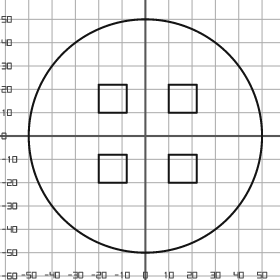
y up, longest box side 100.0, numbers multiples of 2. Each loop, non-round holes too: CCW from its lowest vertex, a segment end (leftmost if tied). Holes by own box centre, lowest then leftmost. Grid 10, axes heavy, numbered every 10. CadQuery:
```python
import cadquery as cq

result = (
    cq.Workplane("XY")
    .moveTo(0.0, 0.0)
    .circle(50.0)
    .moveTo(-20.0, -20.0)
    .lineTo(-8.0, -20.0)
    .lineTo(-8.0, -8.0)
    .lineTo(-20.0, -8.0)
    .close()
    .moveTo(10.0, -20.0)
    .lineTo(22.0, -20.0)
    .lineTo(22.0, -8.0)
    .lineTo(10.0, -8.0)
    .close()
    .moveTo(-20.0, 10.0)
    .lineTo(-8.0, 10.0)
    .lineTo(-8.0, 22.0)
    .lineTo(-20.0, 22.0)
    .close()
    .moveTo(10.0, 10.0)
    .lineTo(22.0, 10.0)
    .lineTo(22.0, 22.0)
    .lineTo(10.0, 22.0)
    .close()
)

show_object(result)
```